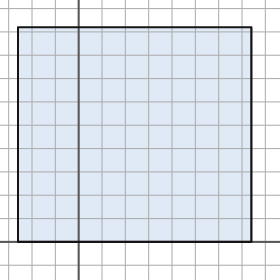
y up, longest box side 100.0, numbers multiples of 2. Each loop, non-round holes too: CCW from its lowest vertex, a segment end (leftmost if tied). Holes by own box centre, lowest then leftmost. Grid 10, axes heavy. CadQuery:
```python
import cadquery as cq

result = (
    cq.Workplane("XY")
    .moveTo(-26.0, 0.0)
    .lineTo(74.0, 0.0)
    .lineTo(74.0, 92.0)
    .lineTo(-26.0, 92.0)
    .close()
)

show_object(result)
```